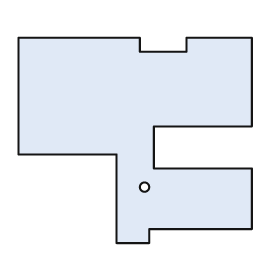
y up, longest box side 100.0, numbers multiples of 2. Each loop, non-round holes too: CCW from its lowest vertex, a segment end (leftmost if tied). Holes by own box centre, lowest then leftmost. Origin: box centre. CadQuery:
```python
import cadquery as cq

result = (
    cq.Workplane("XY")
    .moveTo(-8.0, -44.0)
    .lineTo(6.0, -44.0)
    .lineTo(6.0, -38.0)
    .lineTo(50.0, -38.0)
    .lineTo(50.0, -12.0)
    .lineTo(8.0, -12.0)
    .lineTo(8.0, 6.0)
    .lineTo(50.0, 6.0)
    .lineTo(50.0, 44.0)
    .lineTo(22.0, 44.0)
    .lineTo(22.0, 38.0)
    .lineTo(2.0, 38.0)
    .lineTo(2.0, 44.0)
    .lineTo(-50.0, 44.0)
    .lineTo(-50.0, -6.0)
    .lineTo(-8.0, -6.0)
    .close()
    .moveTo(4.0, -20.0)
    .circle(2.0)
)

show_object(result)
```